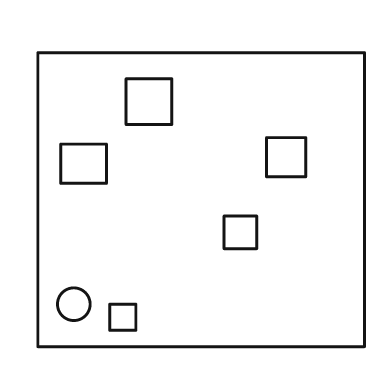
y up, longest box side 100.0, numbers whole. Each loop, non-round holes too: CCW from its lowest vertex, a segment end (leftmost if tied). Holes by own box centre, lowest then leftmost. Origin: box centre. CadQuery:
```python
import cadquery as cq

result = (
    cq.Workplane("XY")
    .moveTo(-50.0, -45.0)
    .lineTo(50.0, -45.0)
    .lineTo(50.0, 45.0)
    .lineTo(-50.0, 45.0)
    .close()
    .moveTo(-28.0, -40.0)
    .lineTo(-20.0, -40.0)
    .lineTo(-20.0, -32.0)
    .lineTo(-28.0, -32.0)
    .close()
    .moveTo(-39.0, -32.0)
    .circle(5.0)
    .moveTo(7.0, -15.0)
    .lineTo(17.0, -15.0)
    .lineTo(17.0, -5.0)
    .lineTo(7.0, -5.0)
    .close()
    .moveTo(-43.0, 5.0)
    .lineTo(-29.0, 5.0)
    .lineTo(-29.0, 17.0)
    .lineTo(-43.0, 17.0)
    .close()
    .moveTo(20.0, 7.0)
    .lineTo(32.0, 7.0)
    .lineTo(32.0, 19.0)
    .lineTo(20.0, 19.0)
    .close()
    .moveTo(-23.0, 23.0)
    .lineTo(-9.0, 23.0)
    .lineTo(-9.0, 37.0)
    .lineTo(-23.0, 37.0)
    .close()
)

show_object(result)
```